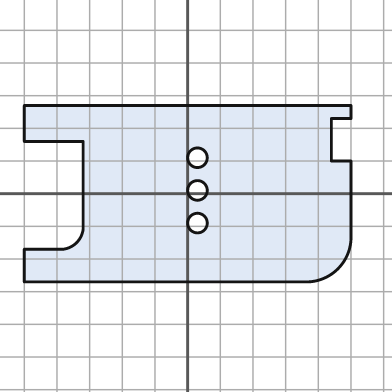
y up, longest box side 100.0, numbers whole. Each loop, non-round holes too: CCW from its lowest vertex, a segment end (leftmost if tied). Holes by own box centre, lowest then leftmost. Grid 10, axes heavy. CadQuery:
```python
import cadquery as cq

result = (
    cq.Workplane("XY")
    .moveTo(-50.0, -27.0)
    .lineTo(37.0, -27.0)
    .threePointArc((46.0, -23.0), (50.0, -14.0))
    .lineTo(50.0, 10.0)
    .lineTo(44.0, 10.0)
    .lineTo(44.0, 23.0)
    .lineTo(50.0, 23.0)
    .lineTo(50.0, 27.0)
    .lineTo(-50.0, 27.0)
    .lineTo(-50.0, 16.0)
    .lineTo(-32.0, 16.0)
    .lineTo(-32.0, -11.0)
    .threePointArc((-34.0, -15.0), (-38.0, -17.0))
    .lineTo(-50.0, -17.0)
    .close()
    .moveTo(3.0, -9.0)
    .circle(3.0)
    .moveTo(3.0, 1.0)
    .circle(3.0)
    .moveTo(3.0, 11.0)
    .circle(3.0)
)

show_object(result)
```